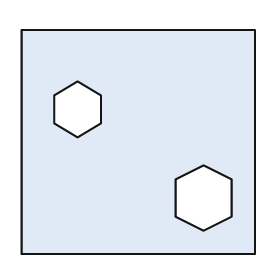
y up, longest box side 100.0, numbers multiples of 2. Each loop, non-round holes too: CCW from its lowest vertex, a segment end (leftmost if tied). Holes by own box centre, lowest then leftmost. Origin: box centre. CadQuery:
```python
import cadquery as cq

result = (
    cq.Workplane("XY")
    .moveTo(-50.0, -48.0)
    .lineTo(50.0, -48.0)
    .lineTo(50.0, 48.0)
    .lineTo(-50.0, 48.0)
    .close()
    .moveTo(28.0, -38.0)
    .lineTo(40.0, -32.0)
    .lineTo(40.0, -16.0)
    .lineTo(28.0, -10.0)
    .lineTo(16.0, -16.0)
    .lineTo(16.0, -32.0)
    .close()
    .moveTo(-26.0, 2.0)
    .lineTo(-16.0, 8.0)
    .lineTo(-16.0, 20.0)
    .lineTo(-26.0, 26.0)
    .lineTo(-36.0, 20.0)
    .lineTo(-36.0, 8.0)
    .close()
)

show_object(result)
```